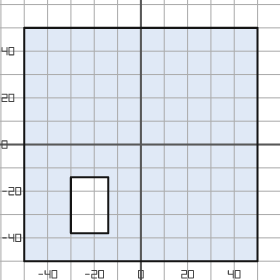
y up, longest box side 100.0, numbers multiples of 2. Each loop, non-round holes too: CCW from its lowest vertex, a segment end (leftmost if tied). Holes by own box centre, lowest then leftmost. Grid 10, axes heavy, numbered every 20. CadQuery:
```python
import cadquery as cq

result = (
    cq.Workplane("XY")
    .moveTo(-50.0, -50.0)
    .lineTo(50.0, -50.0)
    .lineTo(50.0, 50.0)
    .lineTo(-50.0, 50.0)
    .close()
    .moveTo(-30.0, -38.0)
    .lineTo(-14.0, -38.0)
    .lineTo(-14.0, -14.0)
    .lineTo(-30.0, -14.0)
    .close()
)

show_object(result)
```